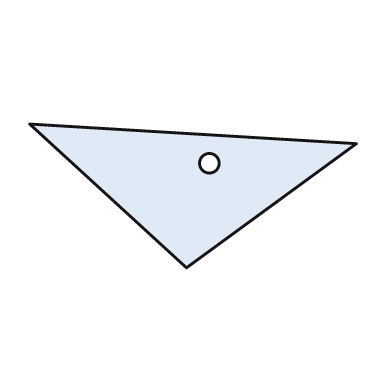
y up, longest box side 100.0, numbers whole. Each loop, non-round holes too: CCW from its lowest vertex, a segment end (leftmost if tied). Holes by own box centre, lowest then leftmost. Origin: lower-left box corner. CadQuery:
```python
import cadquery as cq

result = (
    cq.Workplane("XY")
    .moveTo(48.0, 0.0)
    .lineTo(100.0, 38.0)
    .lineTo(0.0, 44.0)
    .close()
    .moveTo(55.0, 32.0)
    .circle(3.0)
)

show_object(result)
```